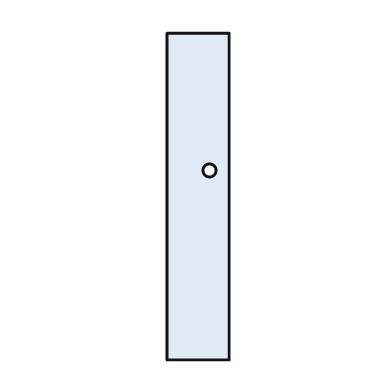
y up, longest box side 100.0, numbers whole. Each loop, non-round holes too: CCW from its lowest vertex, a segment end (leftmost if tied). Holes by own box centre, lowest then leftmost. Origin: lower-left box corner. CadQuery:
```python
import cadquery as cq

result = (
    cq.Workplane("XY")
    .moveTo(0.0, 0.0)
    .lineTo(19.0, 0.0)
    .lineTo(19.0, 100.0)
    .lineTo(0.0, 100.0)
    .close()
    .moveTo(13.0, 58.0)
    .circle(2.0)
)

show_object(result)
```